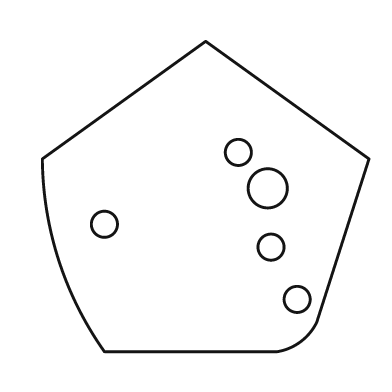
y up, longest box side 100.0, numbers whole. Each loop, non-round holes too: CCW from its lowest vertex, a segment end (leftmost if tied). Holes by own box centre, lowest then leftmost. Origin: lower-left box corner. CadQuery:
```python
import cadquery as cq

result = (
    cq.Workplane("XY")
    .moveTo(19.0, 0.0)
    .lineTo(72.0, 0.0)
    .threePointArc((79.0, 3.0), (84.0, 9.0))
    .lineTo(100.0, 59.0)
    .lineTo(50.0, 95.0)
    .lineTo(0.0, 59.0)
    .threePointArc((5.0, 28.0), (19.0, 0.0))
    .close()
    .moveTo(78.0, 16.0)
    .circle(4.0)
    .moveTo(70.0, 32.0)
    .circle(4.0)
    .moveTo(19.0, 39.0)
    .circle(4.0)
    .moveTo(69.0, 50.0)
    .circle(6.0)
    .moveTo(60.0, 61.0)
    .circle(4.0)
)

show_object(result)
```